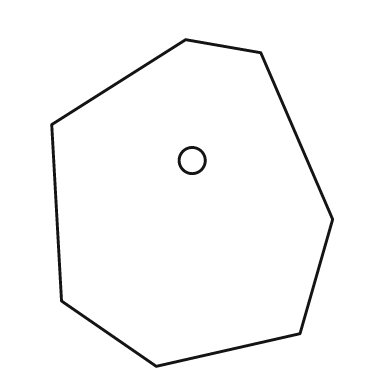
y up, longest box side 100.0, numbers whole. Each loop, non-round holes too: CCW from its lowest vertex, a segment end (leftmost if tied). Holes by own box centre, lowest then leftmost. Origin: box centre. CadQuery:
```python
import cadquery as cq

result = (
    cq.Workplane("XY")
    .moveTo(-11.0, -50.0)
    .lineTo(33.0, -40.0)
    .lineTo(43.0, -5.0)
    .lineTo(21.0, 46.0)
    .lineTo(-2.0, 50.0)
    .lineTo(-43.0, 24.0)
    .lineTo(-40.0, -30.0)
    .close()
    .moveTo(0.0, 13.0)
    .circle(4.0)
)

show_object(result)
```